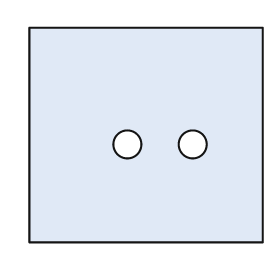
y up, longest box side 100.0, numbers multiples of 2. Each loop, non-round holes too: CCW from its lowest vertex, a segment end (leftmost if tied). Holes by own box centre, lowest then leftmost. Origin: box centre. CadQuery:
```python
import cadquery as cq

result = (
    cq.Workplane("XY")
    .moveTo(-50.0, -46.0)
    .lineTo(50.0, -46.0)
    .lineTo(50.0, 46.0)
    .lineTo(-50.0, 46.0)
    .close()
    .moveTo(-8.0, -4.0)
    .circle(6.0)
    .moveTo(20.0, -4.0)
    .circle(6.0)
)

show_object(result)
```